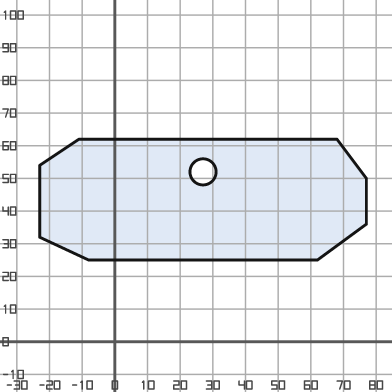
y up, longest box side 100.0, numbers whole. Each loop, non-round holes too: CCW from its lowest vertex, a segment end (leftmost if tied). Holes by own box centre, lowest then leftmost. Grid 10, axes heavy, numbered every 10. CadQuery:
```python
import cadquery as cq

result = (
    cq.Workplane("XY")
    .moveTo(-8.0, 25.0)
    .lineTo(62.0, 25.0)
    .lineTo(77.0, 36.0)
    .lineTo(77.0, 50.0)
    .lineTo(68.0, 62.0)
    .lineTo(-11.0, 62.0)
    .lineTo(-23.0, 54.0)
    .lineTo(-23.0, 32.0)
    .close()
    .moveTo(27.0, 52.0)
    .circle(4.0)
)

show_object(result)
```